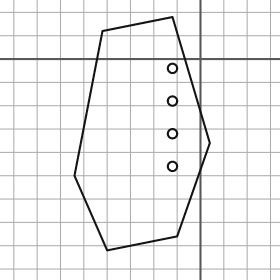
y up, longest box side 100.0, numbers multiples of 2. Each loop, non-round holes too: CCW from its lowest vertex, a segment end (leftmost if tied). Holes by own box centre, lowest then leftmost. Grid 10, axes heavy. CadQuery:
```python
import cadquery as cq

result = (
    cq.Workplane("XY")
    .moveTo(-40.0, -82.0)
    .lineTo(-10.0, -76.0)
    .lineTo(4.0, -36.0)
    .lineTo(-12.0, 18.0)
    .lineTo(-42.0, 12.0)
    .lineTo(-54.0, -50.0)
    .close()
    .moveTo(-12.0, -46.0)
    .circle(2.0)
    .moveTo(-12.0, -32.0)
    .circle(2.0)
    .moveTo(-12.0, -18.0)
    .circle(2.0)
    .moveTo(-12.0, -4.0)
    .circle(2.0)
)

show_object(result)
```